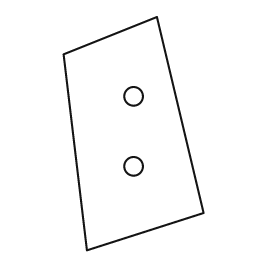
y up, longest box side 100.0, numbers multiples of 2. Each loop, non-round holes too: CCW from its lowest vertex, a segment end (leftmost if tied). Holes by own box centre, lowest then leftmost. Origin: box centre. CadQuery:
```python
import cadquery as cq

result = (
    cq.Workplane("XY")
    .moveTo(-20.0, -50.0)
    .lineTo(30.0, -34.0)
    .lineTo(10.0, 50.0)
    .lineTo(-30.0, 34.0)
    .close()
    .moveTo(0.0, -14.0)
    .circle(4.0)
    .moveTo(0.0, 16.0)
    .circle(4.0)
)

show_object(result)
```